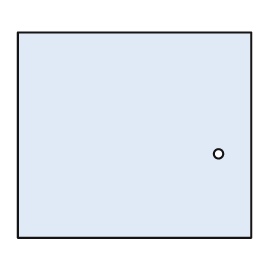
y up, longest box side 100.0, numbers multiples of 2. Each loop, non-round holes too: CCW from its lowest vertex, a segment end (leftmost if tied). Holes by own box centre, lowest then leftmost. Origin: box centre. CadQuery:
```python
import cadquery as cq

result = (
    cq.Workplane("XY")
    .moveTo(-50.0, -44.0)
    .lineTo(50.0, -44.0)
    .lineTo(50.0, 44.0)
    .lineTo(-50.0, 44.0)
    .close()
    .moveTo(36.0, -8.0)
    .circle(2.0)
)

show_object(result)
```